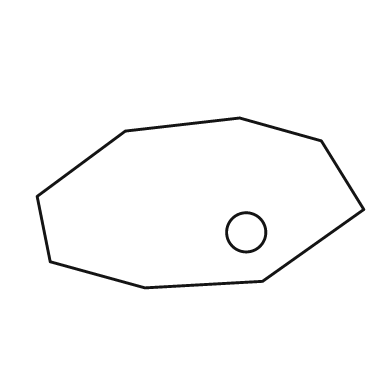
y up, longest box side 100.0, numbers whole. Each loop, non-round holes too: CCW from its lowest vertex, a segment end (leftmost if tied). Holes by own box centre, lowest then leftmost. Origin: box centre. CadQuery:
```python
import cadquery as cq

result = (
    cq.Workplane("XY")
    .moveTo(-17.0, -26.0)
    .lineTo(19.0, -24.0)
    .lineTo(50.0, -2.0)
    .lineTo(37.0, 19.0)
    .lineTo(12.0, 26.0)
    .lineTo(-23.0, 22.0)
    .lineTo(-50.0, 2.0)
    .lineTo(-46.0, -18.0)
    .close()
    .moveTo(14.0, -9.0)
    .circle(6.0)
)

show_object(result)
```